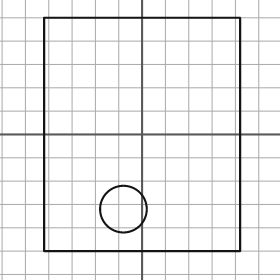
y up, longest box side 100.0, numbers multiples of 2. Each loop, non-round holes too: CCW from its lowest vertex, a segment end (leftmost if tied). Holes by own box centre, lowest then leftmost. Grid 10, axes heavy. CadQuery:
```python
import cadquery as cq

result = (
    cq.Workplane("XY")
    .moveTo(-42.0, -50.0)
    .lineTo(42.0, -50.0)
    .lineTo(42.0, 50.0)
    .lineTo(-42.0, 50.0)
    .close()
    .moveTo(-8.0, -32.0)
    .circle(10.0)
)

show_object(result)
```